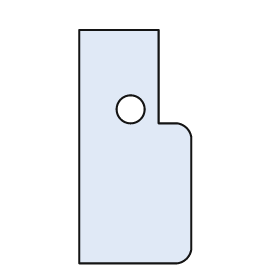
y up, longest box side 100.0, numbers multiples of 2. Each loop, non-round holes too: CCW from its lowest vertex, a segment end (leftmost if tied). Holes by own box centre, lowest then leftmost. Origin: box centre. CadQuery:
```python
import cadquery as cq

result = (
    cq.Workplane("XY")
    .moveTo(-24.0, -50.0)
    .lineTo(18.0, -50.0)
    .threePointArc((22.0, -48.0), (24.0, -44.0))
    .lineTo(24.0, 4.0)
    .threePointArc((22.0, 8.0), (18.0, 10.0))
    .lineTo(10.0, 10.0)
    .lineTo(10.0, 50.0)
    .lineTo(-24.0, 50.0)
    .close()
    .moveTo(-2.0, 16.0)
    .circle(6.0)
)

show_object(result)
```